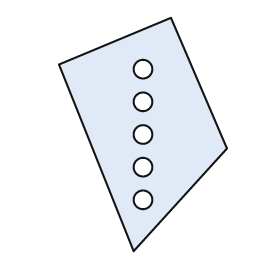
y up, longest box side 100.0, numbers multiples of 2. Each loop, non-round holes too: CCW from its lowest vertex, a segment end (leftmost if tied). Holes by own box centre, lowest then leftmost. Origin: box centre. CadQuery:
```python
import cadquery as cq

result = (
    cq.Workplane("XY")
    .moveTo(-4.0, -50.0)
    .lineTo(36.0, -6.0)
    .lineTo(12.0, 50.0)
    .lineTo(-36.0, 30.0)
    .close()
    .moveTo(0.0, -28.0)
    .circle(4.0)
    .moveTo(0.0, -14.0)
    .circle(4.0)
    .moveTo(0.0, 0.0)
    .circle(4.0)
    .moveTo(0.0, 14.0)
    .circle(4.0)
    .moveTo(0.0, 28.0)
    .circle(4.0)
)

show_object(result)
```